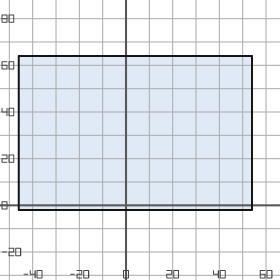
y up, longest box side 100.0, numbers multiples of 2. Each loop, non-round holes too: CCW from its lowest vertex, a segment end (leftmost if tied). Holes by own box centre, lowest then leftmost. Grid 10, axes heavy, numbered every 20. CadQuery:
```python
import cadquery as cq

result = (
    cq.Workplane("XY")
    .moveTo(-46.0, -2.0)
    .lineTo(54.0, -2.0)
    .lineTo(54.0, 64.0)
    .lineTo(-46.0, 64.0)
    .close()
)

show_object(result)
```